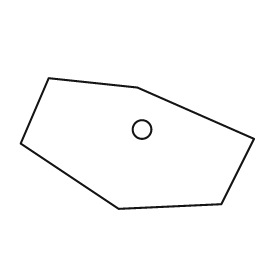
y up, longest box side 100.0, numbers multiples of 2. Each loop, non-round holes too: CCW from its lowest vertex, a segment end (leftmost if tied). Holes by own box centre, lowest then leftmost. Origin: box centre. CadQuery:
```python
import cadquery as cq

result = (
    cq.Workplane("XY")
    .moveTo(-8.0, -28.0)
    .lineTo(36.0, -26.0)
    .lineTo(50.0, 2.0)
    .lineTo(0.0, 24.0)
    .lineTo(-38.0, 28.0)
    .lineTo(-50.0, 0.0)
    .close()
    .moveTo(2.0, 6.0)
    .circle(4.0)
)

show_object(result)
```